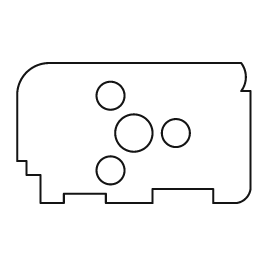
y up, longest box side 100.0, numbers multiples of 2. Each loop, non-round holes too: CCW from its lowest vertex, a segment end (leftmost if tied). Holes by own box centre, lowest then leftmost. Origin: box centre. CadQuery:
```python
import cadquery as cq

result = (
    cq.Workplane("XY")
    .moveTo(-40.0, -30.0)
    .lineTo(-30.0, -30.0)
    .lineTo(-30.0, -26.0)
    .lineTo(-12.0, -26.0)
    .lineTo(-12.0, -30.0)
    .lineTo(8.0, -30.0)
    .lineTo(8.0, -24.0)
    .lineTo(34.0, -24.0)
    .lineTo(34.0, -30.0)
    .lineTo(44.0, -30.0)
    .threePointArc((48.0, -28.0), (50.0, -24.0))
    .lineTo(50.0, 18.0)
    .lineTo(46.0, 18.0)
    .threePointArc((48.0, 24.0), (46.0, 30.0))
    .lineTo(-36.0, 30.0)
    .threePointArc((-46.0, 26.0), (-50.0, 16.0))
    .lineTo(-50.0, -12.0)
    .lineTo(-46.0, -12.0)
    .lineTo(-46.0, -18.0)
    .lineTo(-40.0, -18.0)
    .close()
    .moveTo(-10.0, -16.0)
    .circle(6.0)
    .moveTo(0.0, 0.0)
    .circle(8.0)
    .moveTo(18.0, 0.0)
    .circle(6.0)
    .moveTo(-10.0, 16.0)
    .circle(6.0)
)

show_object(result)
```